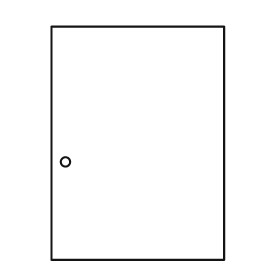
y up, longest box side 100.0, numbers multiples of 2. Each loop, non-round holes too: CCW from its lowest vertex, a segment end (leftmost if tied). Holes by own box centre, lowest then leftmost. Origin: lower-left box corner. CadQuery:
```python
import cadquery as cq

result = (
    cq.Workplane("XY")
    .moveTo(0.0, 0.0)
    .lineTo(74.0, 0.0)
    .lineTo(74.0, 100.0)
    .lineTo(0.0, 100.0)
    .close()
    .moveTo(6.0, 42.0)
    .circle(2.0)
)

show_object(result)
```